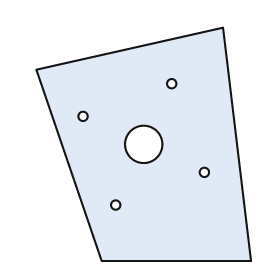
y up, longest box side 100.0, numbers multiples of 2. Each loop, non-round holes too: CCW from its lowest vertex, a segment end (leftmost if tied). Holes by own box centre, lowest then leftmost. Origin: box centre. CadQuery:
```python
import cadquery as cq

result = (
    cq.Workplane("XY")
    .moveTo(-18.0, -50.0)
    .lineTo(46.0, -50.0)
    .lineTo(34.0, 50.0)
    .lineTo(-46.0, 32.0)
    .close()
    .moveTo(-12.0, -26.0)
    .circle(2.0)
    .moveTo(26.0, -12.0)
    .circle(2.0)
    .moveTo(0.0, 0.0)
    .circle(8.0)
    .moveTo(-26.0, 12.0)
    .circle(2.0)
    .moveTo(12.0, 26.0)
    .circle(2.0)
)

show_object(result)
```